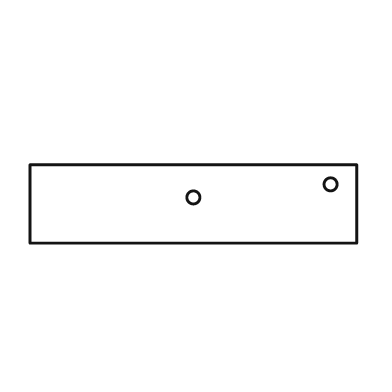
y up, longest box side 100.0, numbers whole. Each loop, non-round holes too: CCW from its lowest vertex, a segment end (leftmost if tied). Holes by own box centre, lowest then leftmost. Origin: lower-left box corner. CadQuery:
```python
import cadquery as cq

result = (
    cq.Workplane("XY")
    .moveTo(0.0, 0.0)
    .lineTo(100.0, 0.0)
    .lineTo(100.0, 24.0)
    .lineTo(0.0, 24.0)
    .close()
    .moveTo(50.0, 14.0)
    .circle(2.0)
    .moveTo(92.0, 18.0)
    .circle(2.0)
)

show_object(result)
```